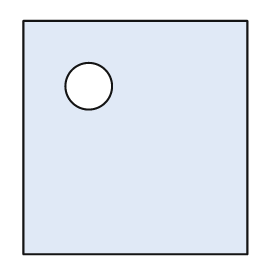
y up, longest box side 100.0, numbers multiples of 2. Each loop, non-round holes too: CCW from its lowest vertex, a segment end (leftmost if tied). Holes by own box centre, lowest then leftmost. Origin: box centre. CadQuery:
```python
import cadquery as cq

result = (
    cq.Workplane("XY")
    .moveTo(-48.0, -50.0)
    .lineTo(48.0, -50.0)
    .lineTo(48.0, 50.0)
    .lineTo(-48.0, 50.0)
    .close()
    .moveTo(-20.0, 22.0)
    .circle(10.0)
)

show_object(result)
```